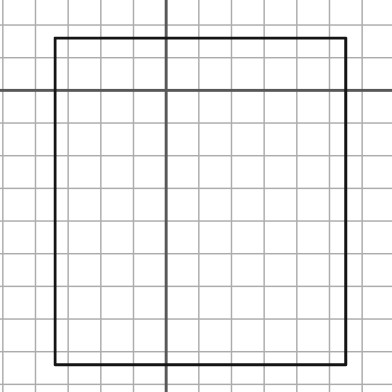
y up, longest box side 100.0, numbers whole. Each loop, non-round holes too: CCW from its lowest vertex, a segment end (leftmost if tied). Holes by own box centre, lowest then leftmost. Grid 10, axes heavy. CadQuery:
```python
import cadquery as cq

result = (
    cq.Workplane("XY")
    .moveTo(-34.0, -84.0)
    .lineTo(55.0, -84.0)
    .lineTo(55.0, 16.0)
    .lineTo(-34.0, 16.0)
    .close()
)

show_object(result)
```